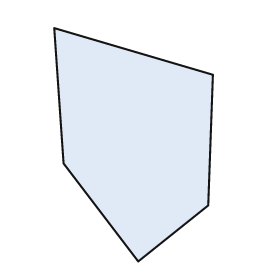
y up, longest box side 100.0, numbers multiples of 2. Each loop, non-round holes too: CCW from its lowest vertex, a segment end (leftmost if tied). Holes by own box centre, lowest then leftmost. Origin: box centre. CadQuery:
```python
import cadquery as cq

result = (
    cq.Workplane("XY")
    .moveTo(2.0, -50.0)
    .lineTo(32.0, -26.0)
    .lineTo(34.0, 30.0)
    .lineTo(-34.0, 50.0)
    .lineTo(-30.0, -8.0)
    .close()
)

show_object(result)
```